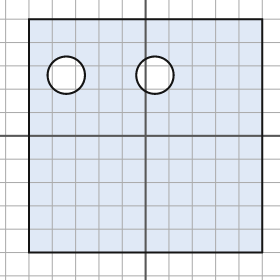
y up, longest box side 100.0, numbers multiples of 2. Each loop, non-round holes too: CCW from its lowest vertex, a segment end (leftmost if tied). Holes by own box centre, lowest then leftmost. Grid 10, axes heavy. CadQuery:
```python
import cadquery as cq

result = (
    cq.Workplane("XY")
    .moveTo(-50.0, -50.0)
    .lineTo(50.0, -50.0)
    .lineTo(50.0, 50.0)
    .lineTo(-50.0, 50.0)
    .close()
    .moveTo(-34.0, 26.0)
    .circle(8.0)
    .moveTo(4.0, 26.0)
    .circle(8.0)
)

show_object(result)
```